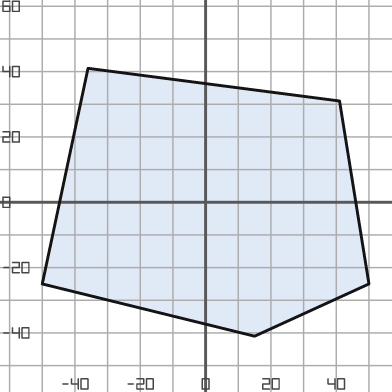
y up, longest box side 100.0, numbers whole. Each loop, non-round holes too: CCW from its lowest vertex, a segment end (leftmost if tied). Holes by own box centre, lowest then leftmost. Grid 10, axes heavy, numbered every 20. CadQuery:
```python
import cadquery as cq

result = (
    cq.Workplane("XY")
    .moveTo(15.0, -41.0)
    .lineTo(50.0, -25.0)
    .lineTo(41.0, 31.0)
    .lineTo(-36.0, 41.0)
    .lineTo(-50.0, -25.0)
    .close()
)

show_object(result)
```